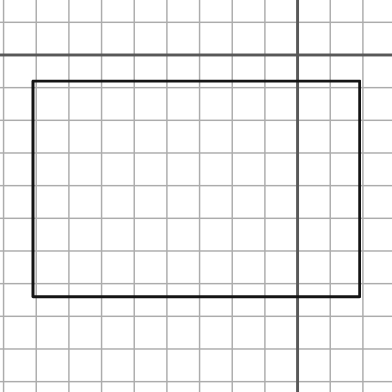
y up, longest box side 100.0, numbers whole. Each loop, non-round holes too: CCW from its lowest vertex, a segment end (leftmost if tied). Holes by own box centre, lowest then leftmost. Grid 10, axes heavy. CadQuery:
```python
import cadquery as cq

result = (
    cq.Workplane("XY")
    .moveTo(-81.0, -74.0)
    .lineTo(19.0, -74.0)
    .lineTo(19.0, -8.0)
    .lineTo(-81.0, -8.0)
    .close()
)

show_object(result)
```